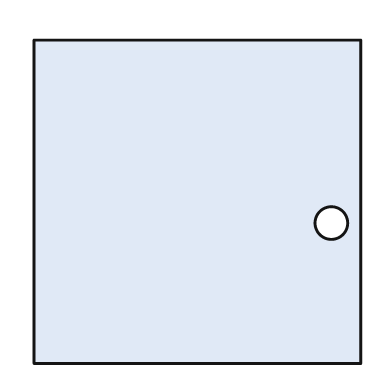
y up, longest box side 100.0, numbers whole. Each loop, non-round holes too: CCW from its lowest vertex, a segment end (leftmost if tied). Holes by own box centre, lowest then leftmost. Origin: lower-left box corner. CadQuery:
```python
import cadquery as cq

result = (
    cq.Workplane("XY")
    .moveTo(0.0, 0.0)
    .lineTo(100.0, 0.0)
    .lineTo(100.0, 99.0)
    .lineTo(0.0, 99.0)
    .close()
    .moveTo(91.0, 43.0)
    .circle(5.0)
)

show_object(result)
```